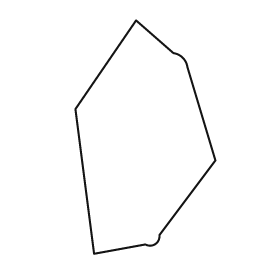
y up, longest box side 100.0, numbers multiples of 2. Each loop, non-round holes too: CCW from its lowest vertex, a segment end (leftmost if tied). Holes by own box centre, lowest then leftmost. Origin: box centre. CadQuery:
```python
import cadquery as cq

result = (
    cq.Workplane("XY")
    .moveTo(-22.0, -50.0)
    .lineTo(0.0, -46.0)
    .threePointArc((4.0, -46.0), (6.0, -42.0))
    .lineTo(30.0, -10.0)
    .lineTo(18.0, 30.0)
    .threePointArc((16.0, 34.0), (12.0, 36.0))
    .lineTo(-4.0, 50.0)
    .lineTo(-30.0, 12.0)
    .close()
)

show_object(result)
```